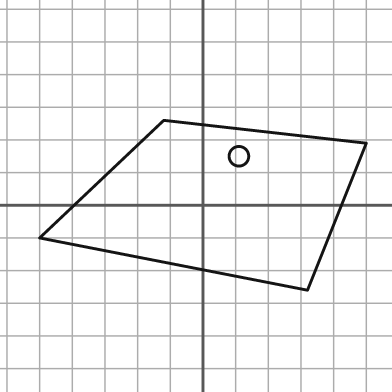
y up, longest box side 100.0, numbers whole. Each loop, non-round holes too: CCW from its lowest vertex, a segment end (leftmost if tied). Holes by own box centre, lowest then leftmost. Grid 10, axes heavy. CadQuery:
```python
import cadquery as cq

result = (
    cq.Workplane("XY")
    .moveTo(32.0, -26.0)
    .lineTo(50.0, 19.0)
    .lineTo(-12.0, 26.0)
    .lineTo(-50.0, -10.0)
    .close()
    .moveTo(11.0, 15.0)
    .circle(3.0)
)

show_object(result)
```